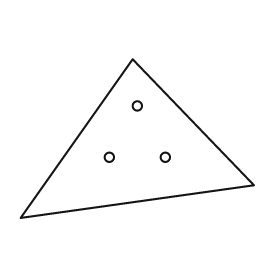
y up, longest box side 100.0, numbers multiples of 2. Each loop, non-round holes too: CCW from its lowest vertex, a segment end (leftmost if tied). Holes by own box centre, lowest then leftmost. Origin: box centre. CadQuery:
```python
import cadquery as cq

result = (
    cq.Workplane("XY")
    .moveTo(-50.0, -34.0)
    .lineTo(50.0, -20.0)
    .lineTo(-2.0, 34.0)
    .close()
    .moveTo(-12.0, -8.0)
    .circle(2.0)
    .moveTo(12.0, -8.0)
    .circle(2.0)
    .moveTo(0.0, 14.0)
    .circle(2.0)
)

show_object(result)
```